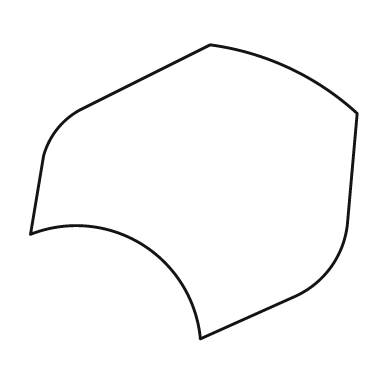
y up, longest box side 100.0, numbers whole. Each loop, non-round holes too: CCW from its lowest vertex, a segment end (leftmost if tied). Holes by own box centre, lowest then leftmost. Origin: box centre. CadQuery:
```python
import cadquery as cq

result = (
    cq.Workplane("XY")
    .moveTo(2.0, -45.0)
    .lineTo(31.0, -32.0)
    .threePointArc((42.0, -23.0), (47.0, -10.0))
    .lineTo(50.0, 24.0)
    .threePointArc((29.0, 38.0), (5.0, 45.0))
    .lineTo(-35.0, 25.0)
    .threePointArc((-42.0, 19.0), (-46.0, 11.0))
    .lineTo(-50.0, -13.0)
    .threePointArc((-16.0, -16.0), (2.0, -45.0))
    .close()
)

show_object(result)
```